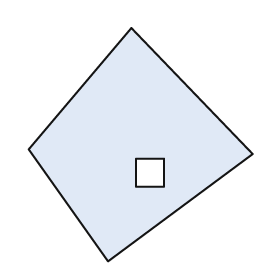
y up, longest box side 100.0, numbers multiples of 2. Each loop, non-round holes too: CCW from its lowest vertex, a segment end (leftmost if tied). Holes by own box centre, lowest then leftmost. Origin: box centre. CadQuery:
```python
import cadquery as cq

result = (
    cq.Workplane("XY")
    .moveTo(-14.0, -50.0)
    .lineTo(48.0, -4.0)
    .lineTo(-4.0, 50.0)
    .lineTo(-48.0, -2.0)
    .close()
    .moveTo(-2.0, -18.0)
    .lineTo(10.0, -18.0)
    .lineTo(10.0, -6.0)
    .lineTo(-2.0, -6.0)
    .close()
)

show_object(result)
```